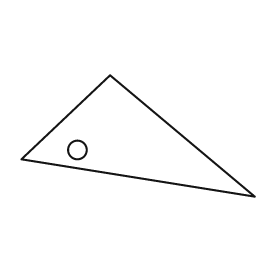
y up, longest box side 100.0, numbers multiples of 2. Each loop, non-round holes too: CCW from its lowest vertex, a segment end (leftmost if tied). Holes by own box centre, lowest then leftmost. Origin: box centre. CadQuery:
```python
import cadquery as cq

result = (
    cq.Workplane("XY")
    .moveTo(50.0, -26.0)
    .lineTo(-12.0, 26.0)
    .lineTo(-50.0, -10.0)
    .close()
    .moveTo(-26.0, -6.0)
    .circle(4.0)
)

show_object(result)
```